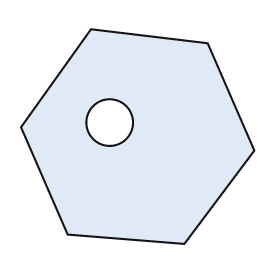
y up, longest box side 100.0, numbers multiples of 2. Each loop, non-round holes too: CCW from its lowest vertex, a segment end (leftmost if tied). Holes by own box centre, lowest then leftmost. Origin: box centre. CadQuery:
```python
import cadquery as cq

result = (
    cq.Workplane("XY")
    .moveTo(20.0, -46.0)
    .lineTo(50.0, -6.0)
    .lineTo(30.0, 40.0)
    .lineTo(-20.0, 46.0)
    .lineTo(-50.0, 4.0)
    .lineTo(-30.0, -42.0)
    .close()
    .moveTo(-12.0, 6.0)
    .circle(10.0)
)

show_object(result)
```